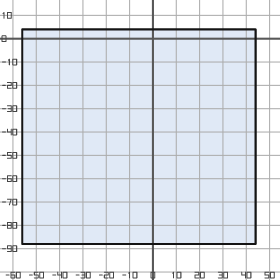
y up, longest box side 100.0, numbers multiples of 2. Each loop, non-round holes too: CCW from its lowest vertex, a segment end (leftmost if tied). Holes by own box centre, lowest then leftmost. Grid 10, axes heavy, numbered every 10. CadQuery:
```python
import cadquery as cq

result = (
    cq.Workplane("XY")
    .moveTo(-56.0, -88.0)
    .lineTo(44.0, -88.0)
    .lineTo(44.0, 4.0)
    .lineTo(-56.0, 4.0)
    .close()
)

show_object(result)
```